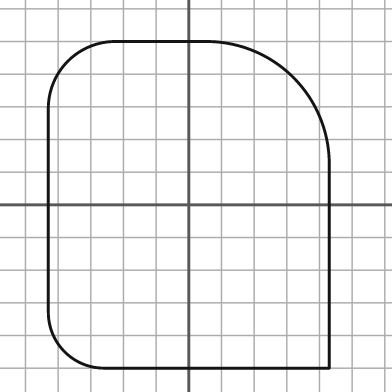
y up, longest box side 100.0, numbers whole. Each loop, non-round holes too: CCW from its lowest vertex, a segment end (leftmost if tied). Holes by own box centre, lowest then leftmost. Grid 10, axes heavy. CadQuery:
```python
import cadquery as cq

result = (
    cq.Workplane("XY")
    .moveTo(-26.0, -50.0)
    .lineTo(43.0, -50.0)
    .lineTo(43.0, 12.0)
    .threePointArc((32.0, 39.0), (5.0, 50.0))
    .lineTo(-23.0, 50.0)
    .threePointArc((-37.0, 44.0), (-43.0, 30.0))
    .lineTo(-43.0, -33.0)
    .threePointArc((-38.0, -45.0), (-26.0, -50.0))
    .close()
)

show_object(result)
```